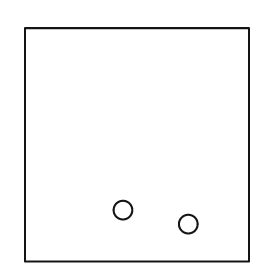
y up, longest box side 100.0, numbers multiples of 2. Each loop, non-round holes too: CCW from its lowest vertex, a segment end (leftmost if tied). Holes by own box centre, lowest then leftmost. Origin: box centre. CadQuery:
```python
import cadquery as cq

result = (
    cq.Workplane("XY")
    .moveTo(-48.0, -50.0)
    .lineTo(48.0, -50.0)
    .lineTo(48.0, 50.0)
    .lineTo(-48.0, 50.0)
    .close()
    .moveTo(22.0, -34.0)
    .circle(4.0)
    .moveTo(-6.0, -28.0)
    .circle(4.0)
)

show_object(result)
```